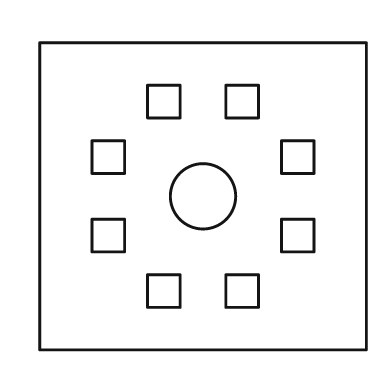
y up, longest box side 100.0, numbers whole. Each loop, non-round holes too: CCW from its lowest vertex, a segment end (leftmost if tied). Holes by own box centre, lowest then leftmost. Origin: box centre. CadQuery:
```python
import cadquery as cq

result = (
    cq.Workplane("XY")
    .moveTo(-50.0, -47.0)
    .lineTo(50.0, -47.0)
    .lineTo(50.0, 47.0)
    .lineTo(-50.0, 47.0)
    .close()
    .moveTo(-17.0, -34.0)
    .lineTo(-7.0, -34.0)
    .lineTo(-7.0, -24.0)
    .lineTo(-17.0, -24.0)
    .close()
    .moveTo(7.0, -34.0)
    .lineTo(17.0, -34.0)
    .lineTo(17.0, -24.0)
    .lineTo(7.0, -24.0)
    .close()
    .moveTo(-34.0, -17.0)
    .lineTo(-24.0, -17.0)
    .lineTo(-24.0, -7.0)
    .lineTo(-34.0, -7.0)
    .close()
    .moveTo(24.0, -17.0)
    .lineTo(34.0, -17.0)
    .lineTo(34.0, -7.0)
    .lineTo(24.0, -7.0)
    .close()
    .moveTo(0.0, 0.0)
    .circle(10.0)
    .moveTo(-34.0, 7.0)
    .lineTo(-24.0, 7.0)
    .lineTo(-24.0, 17.0)
    .lineTo(-34.0, 17.0)
    .close()
    .moveTo(24.0, 7.0)
    .lineTo(34.0, 7.0)
    .lineTo(34.0, 17.0)
    .lineTo(24.0, 17.0)
    .close()
    .moveTo(-17.0, 24.0)
    .lineTo(-7.0, 24.0)
    .lineTo(-7.0, 34.0)
    .lineTo(-17.0, 34.0)
    .close()
    .moveTo(7.0, 24.0)
    .lineTo(17.0, 24.0)
    .lineTo(17.0, 34.0)
    .lineTo(7.0, 34.0)
    .close()
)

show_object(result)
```